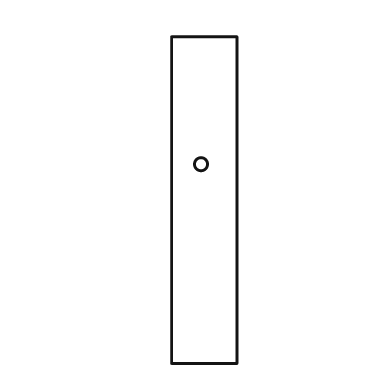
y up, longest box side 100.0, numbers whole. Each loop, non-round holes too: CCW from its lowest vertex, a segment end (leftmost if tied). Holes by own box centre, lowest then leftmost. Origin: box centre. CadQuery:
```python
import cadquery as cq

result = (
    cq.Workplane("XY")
    .moveTo(-10.0, -50.0)
    .lineTo(10.0, -50.0)
    .lineTo(10.0, 50.0)
    .lineTo(-10.0, 50.0)
    .close()
    .moveTo(-1.0, 11.0)
    .circle(2.0)
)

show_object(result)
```